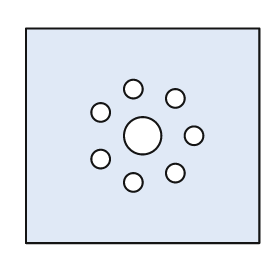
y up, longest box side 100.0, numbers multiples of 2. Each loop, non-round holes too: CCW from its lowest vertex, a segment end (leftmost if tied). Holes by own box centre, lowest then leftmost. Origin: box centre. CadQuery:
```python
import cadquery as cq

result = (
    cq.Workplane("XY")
    .moveTo(-50.0, -46.0)
    .lineTo(50.0, -46.0)
    .lineTo(50.0, 46.0)
    .lineTo(-50.0, 46.0)
    .close()
    .moveTo(-4.0, -20.0)
    .circle(4.0)
    .moveTo(14.0, -16.0)
    .circle(4.0)
    .moveTo(-18.0, -10.0)
    .circle(4.0)
    .moveTo(0.0, 0.0)
    .circle(8.0)
    .moveTo(22.0, 0.0)
    .circle(4.0)
    .moveTo(-18.0, 10.0)
    .circle(4.0)
    .moveTo(14.0, 16.0)
    .circle(4.0)
    .moveTo(-4.0, 20.0)
    .circle(4.0)
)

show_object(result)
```